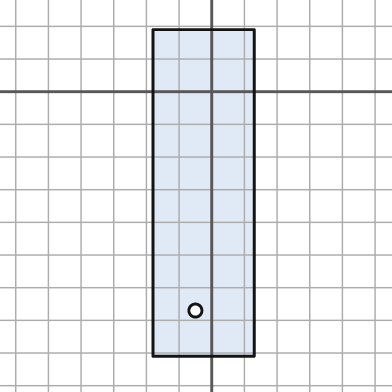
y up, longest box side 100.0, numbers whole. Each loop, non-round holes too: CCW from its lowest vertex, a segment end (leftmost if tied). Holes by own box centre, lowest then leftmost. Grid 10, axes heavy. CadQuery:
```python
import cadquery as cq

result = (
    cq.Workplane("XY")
    .moveTo(-18.0, -81.0)
    .lineTo(13.0, -81.0)
    .lineTo(13.0, 19.0)
    .lineTo(-18.0, 19.0)
    .close()
    .moveTo(-5.0, -67.0)
    .circle(2.0)
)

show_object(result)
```